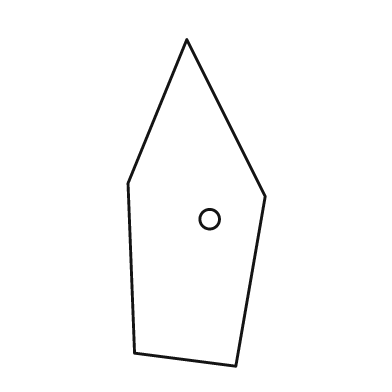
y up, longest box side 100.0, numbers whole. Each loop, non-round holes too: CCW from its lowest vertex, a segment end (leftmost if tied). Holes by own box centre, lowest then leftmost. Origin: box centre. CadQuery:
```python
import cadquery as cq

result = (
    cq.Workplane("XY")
    .moveTo(12.0, -50.0)
    .lineTo(21.0, 2.0)
    .lineTo(-3.0, 50.0)
    .lineTo(-21.0, 6.0)
    .lineTo(-19.0, -46.0)
    .close()
    .moveTo(4.0, -5.0)
    .circle(3.0)
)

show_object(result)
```